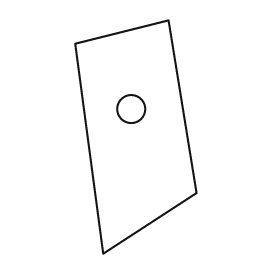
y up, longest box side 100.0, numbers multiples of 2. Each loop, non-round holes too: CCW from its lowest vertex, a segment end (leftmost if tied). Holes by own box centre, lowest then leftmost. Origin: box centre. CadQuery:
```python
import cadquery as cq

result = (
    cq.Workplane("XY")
    .moveTo(-14.0, -50.0)
    .lineTo(26.0, -24.0)
    .lineTo(14.0, 50.0)
    .lineTo(-26.0, 40.0)
    .close()
    .moveTo(-2.0, 12.0)
    .circle(6.0)
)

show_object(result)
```